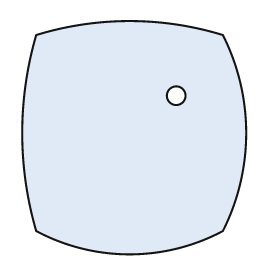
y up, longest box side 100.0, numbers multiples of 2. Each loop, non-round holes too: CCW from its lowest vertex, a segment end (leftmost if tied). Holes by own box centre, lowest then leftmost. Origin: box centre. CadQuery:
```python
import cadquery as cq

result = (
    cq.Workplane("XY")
    .moveTo(-42.0, -40.0)
    .threePointArc((-2.0, -50.0), (38.0, -40.0))
    .threePointArc((48.0, 2.0), (38.0, 44.0))
    .threePointArc((-2.0, 50.0), (-42.0, 44.0))
    .threePointArc((-48.0, 2.0), (-42.0, -40.0))
    .close()
    .moveTo(18.0, 18.0)
    .circle(4.0)
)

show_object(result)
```